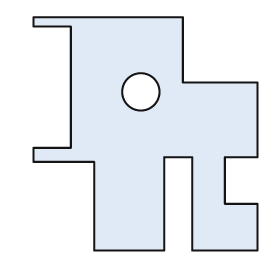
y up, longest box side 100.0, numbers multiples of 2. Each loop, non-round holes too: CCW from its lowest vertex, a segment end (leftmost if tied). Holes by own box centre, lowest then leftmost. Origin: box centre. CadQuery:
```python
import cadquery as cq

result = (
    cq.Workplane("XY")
    .moveTo(-22.0, -50.0)
    .lineTo(8.0, -50.0)
    .lineTo(8.0, -10.0)
    .lineTo(20.0, -10.0)
    .lineTo(20.0, -50.0)
    .lineTo(48.0, -50.0)
    .lineTo(48.0, -30.0)
    .lineTo(34.0, -30.0)
    .lineTo(34.0, -10.0)
    .lineTo(48.0, -10.0)
    .lineTo(48.0, 22.0)
    .lineTo(16.0, 22.0)
    .lineTo(16.0, 50.0)
    .lineTo(-48.0, 50.0)
    .lineTo(-48.0, 46.0)
    .lineTo(-32.0, 46.0)
    .lineTo(-32.0, -6.0)
    .lineTo(-48.0, -6.0)
    .lineTo(-48.0, -12.0)
    .lineTo(-22.0, -12.0)
    .close()
    .moveTo(-2.0, 18.0)
    .circle(8.0)
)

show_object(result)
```